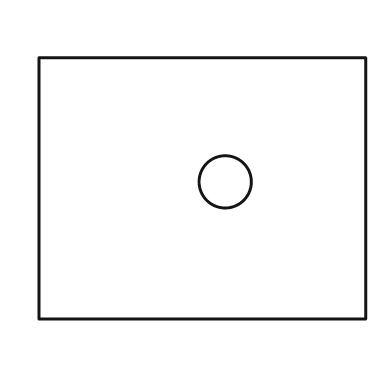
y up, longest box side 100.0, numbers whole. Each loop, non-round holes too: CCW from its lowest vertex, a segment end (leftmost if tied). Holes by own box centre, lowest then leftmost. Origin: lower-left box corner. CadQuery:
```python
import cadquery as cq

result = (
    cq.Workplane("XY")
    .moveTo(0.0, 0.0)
    .lineTo(100.0, 0.0)
    .lineTo(100.0, 80.0)
    .lineTo(0.0, 80.0)
    .close()
    .moveTo(57.0, 42.0)
    .circle(8.0)
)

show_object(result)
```